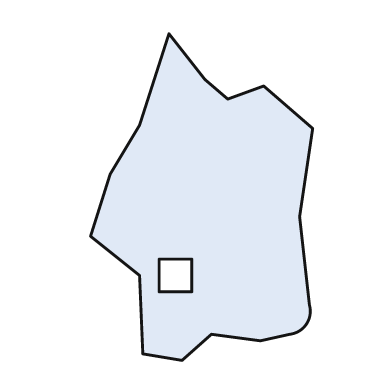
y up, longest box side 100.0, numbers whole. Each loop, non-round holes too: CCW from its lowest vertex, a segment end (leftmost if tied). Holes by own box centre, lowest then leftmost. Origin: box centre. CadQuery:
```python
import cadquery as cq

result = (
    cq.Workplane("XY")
    .moveTo(-6.0, -50.0)
    .lineTo(3.0, -42.0)
    .lineTo(18.0, -44.0)
    .lineTo(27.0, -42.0)
    .threePointArc((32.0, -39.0), (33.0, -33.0))
    .lineTo(30.0, -6.0)
    .lineTo(34.0, 21.0)
    .lineTo(19.0, 34.0)
    .lineTo(8.0, 30.0)
    .lineTo(1.0, 36.0)
    .lineTo(-10.0, 50.0)
    .lineTo(-19.0, 22.0)
    .lineTo(-28.0, 7.0)
    .lineTo(-34.0, -12.0)
    .lineTo(-19.0, -24.0)
    .lineTo(-18.0, -48.0)
    .close()
    .moveTo(-13.0, -29.0)
    .lineTo(-3.0, -29.0)
    .lineTo(-3.0, -19.0)
    .lineTo(-13.0, -19.0)
    .close()
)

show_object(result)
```